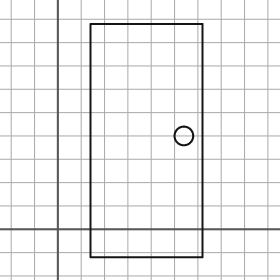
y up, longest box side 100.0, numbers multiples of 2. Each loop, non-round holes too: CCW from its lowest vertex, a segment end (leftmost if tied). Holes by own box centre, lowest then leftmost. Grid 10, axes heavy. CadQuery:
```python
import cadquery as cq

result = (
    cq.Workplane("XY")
    .moveTo(14.0, -12.0)
    .lineTo(62.0, -12.0)
    .lineTo(62.0, 88.0)
    .lineTo(14.0, 88.0)
    .close()
    .moveTo(54.0, 40.0)
    .circle(4.0)
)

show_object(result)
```